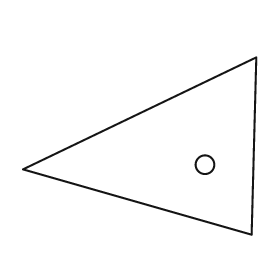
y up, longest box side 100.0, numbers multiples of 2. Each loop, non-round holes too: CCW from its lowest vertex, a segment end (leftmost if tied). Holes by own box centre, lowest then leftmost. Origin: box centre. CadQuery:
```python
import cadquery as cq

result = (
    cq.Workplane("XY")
    .moveTo(48.0, -38.0)
    .lineTo(50.0, 38.0)
    .lineTo(-50.0, -10.0)
    .close()
    .moveTo(28.0, -8.0)
    .circle(4.0)
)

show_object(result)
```